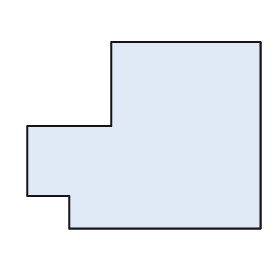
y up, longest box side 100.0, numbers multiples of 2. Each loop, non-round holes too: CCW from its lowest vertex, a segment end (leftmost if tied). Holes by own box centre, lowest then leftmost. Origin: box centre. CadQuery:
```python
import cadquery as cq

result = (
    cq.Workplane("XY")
    .moveTo(-32.0, -40.0)
    .lineTo(50.0, -40.0)
    .lineTo(50.0, 40.0)
    .lineTo(-14.0, 40.0)
    .lineTo(-14.0, 4.0)
    .lineTo(-50.0, 4.0)
    .lineTo(-50.0, -26.0)
    .lineTo(-32.0, -26.0)
    .close()
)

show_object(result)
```